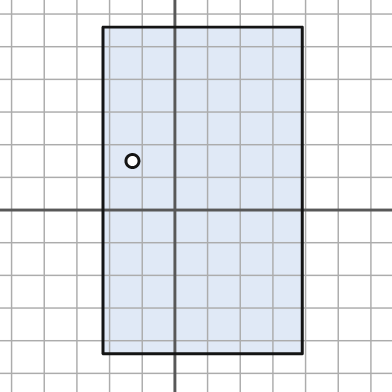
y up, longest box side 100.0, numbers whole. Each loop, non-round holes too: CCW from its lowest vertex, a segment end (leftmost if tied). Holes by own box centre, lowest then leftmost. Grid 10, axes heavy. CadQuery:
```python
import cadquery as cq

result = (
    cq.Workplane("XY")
    .moveTo(-22.0, -44.0)
    .lineTo(39.0, -44.0)
    .lineTo(39.0, 56.0)
    .lineTo(-22.0, 56.0)
    .close()
    .moveTo(-13.0, 15.0)
    .circle(2.0)
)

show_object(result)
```